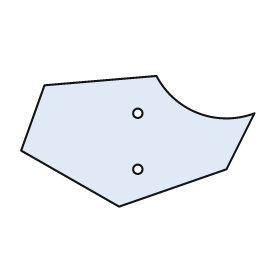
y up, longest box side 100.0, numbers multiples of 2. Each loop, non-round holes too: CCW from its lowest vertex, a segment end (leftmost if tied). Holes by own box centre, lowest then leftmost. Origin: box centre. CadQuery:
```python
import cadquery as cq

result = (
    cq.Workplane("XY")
    .moveTo(-8.0, -28.0)
    .lineTo(38.0, -12.0)
    .lineTo(50.0, 12.0)
    .threePointArc((26.0, 12.0), (8.0, 28.0))
    .lineTo(-40.0, 24.0)
    .lineTo(-50.0, -4.0)
    .close()
    .moveTo(0.0, -12.0)
    .circle(2.0)
    .moveTo(0.0, 12.0)
    .circle(2.0)
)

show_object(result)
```